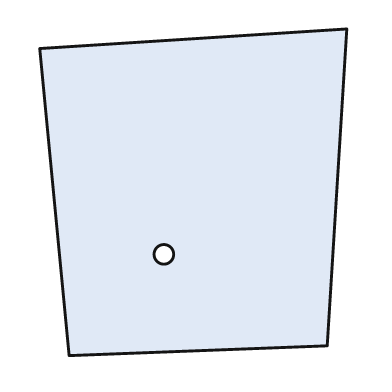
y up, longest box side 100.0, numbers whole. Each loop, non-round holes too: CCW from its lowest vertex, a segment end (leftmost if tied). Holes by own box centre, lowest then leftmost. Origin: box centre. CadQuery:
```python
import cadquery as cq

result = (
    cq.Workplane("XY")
    .moveTo(-38.0, -50.0)
    .lineTo(41.0, -47.0)
    .lineTo(47.0, 50.0)
    .lineTo(-47.0, 44.0)
    .close()
    .moveTo(-9.0, -19.0)
    .circle(3.0)
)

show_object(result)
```